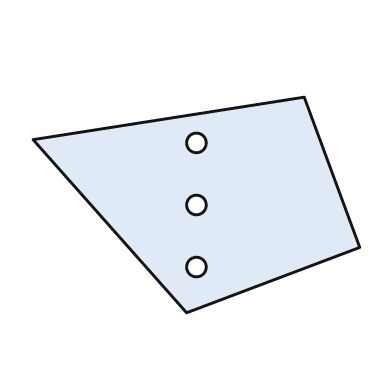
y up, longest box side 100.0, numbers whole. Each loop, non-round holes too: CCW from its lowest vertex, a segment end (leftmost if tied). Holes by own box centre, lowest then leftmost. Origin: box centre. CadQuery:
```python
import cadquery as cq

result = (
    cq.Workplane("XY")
    .moveTo(-3.0, -33.0)
    .lineTo(50.0, -13.0)
    .lineTo(33.0, 33.0)
    .lineTo(-50.0, 20.0)
    .close()
    .moveTo(0.0, -19.0)
    .circle(3.0)
    .moveTo(0.0, 0.0)
    .circle(3.0)
    .moveTo(0.0, 19.0)
    .circle(3.0)
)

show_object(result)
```